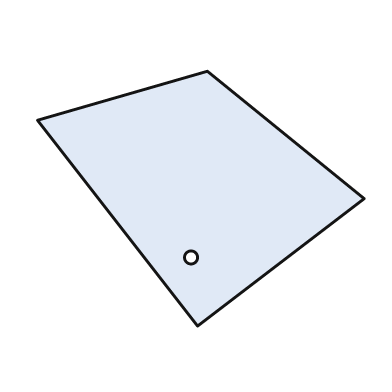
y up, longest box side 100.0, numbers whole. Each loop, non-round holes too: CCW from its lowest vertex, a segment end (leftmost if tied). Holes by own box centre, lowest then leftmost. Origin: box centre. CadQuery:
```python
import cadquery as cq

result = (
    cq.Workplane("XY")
    .moveTo(-1.0, -39.0)
    .lineTo(50.0, 0.0)
    .lineTo(2.0, 39.0)
    .lineTo(-50.0, 24.0)
    .close()
    .moveTo(-3.0, -18.0)
    .circle(2.0)
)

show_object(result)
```